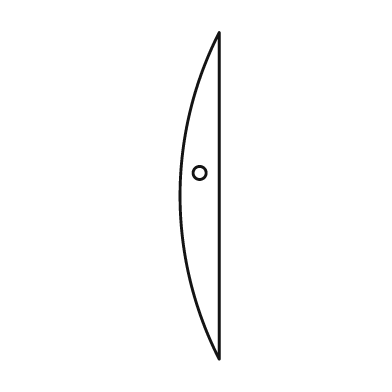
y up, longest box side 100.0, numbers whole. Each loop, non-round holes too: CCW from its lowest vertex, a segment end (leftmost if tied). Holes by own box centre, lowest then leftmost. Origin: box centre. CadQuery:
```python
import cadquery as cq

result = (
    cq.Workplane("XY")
    .moveTo(6.0, -50.0)
    .lineTo(6.0, 50.0)
    .threePointArc((-6.0, 0.0), (6.0, -50.0))
    .close()
    .moveTo(0.0, 7.0)
    .circle(2.0)
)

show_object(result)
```